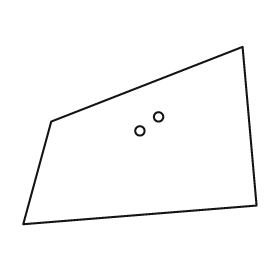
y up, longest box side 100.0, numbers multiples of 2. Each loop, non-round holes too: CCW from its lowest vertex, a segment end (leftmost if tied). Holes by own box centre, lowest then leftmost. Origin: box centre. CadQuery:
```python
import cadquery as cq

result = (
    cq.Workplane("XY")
    .moveTo(-50.0, -38.0)
    .lineTo(50.0, -30.0)
    .lineTo(44.0, 38.0)
    .lineTo(-38.0, 6.0)
    .close()
    .moveTo(0.0, 2.0)
    .circle(2.0)
    .moveTo(8.0, 8.0)
    .circle(2.0)
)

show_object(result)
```